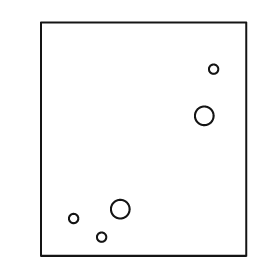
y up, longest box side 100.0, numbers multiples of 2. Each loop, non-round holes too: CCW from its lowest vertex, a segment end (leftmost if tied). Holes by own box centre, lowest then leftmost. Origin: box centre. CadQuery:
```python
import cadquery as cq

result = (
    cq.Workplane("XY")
    .moveTo(-44.0, -50.0)
    .lineTo(44.0, -50.0)
    .lineTo(44.0, 50.0)
    .lineTo(-44.0, 50.0)
    .close()
    .moveTo(-18.0, -42.0)
    .circle(2.0)
    .moveTo(-30.0, -34.0)
    .circle(2.0)
    .moveTo(-10.0, -30.0)
    .circle(4.0)
    .moveTo(26.0, 10.0)
    .circle(4.0)
    .moveTo(30.0, 30.0)
    .circle(2.0)
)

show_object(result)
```